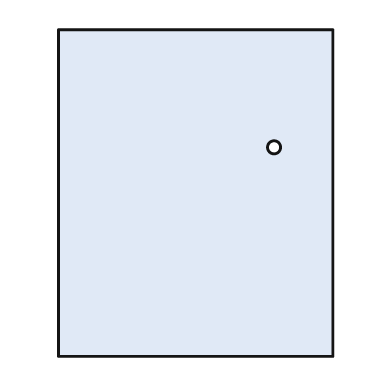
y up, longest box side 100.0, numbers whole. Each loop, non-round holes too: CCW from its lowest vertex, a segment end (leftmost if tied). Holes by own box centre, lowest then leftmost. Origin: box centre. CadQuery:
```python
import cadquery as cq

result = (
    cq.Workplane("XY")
    .moveTo(-42.0, -50.0)
    .lineTo(42.0, -50.0)
    .lineTo(42.0, 50.0)
    .lineTo(-42.0, 50.0)
    .close()
    .moveTo(24.0, 14.0)
    .circle(2.0)
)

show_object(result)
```